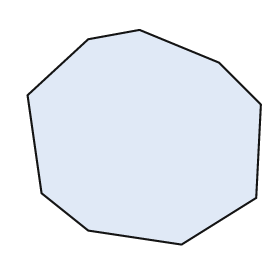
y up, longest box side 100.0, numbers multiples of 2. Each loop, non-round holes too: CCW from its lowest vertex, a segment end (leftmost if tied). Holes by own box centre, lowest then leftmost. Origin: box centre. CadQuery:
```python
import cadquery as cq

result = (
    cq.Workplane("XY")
    .moveTo(16.0, -46.0)
    .lineTo(48.0, -26.0)
    .lineTo(50.0, 14.0)
    .lineTo(32.0, 32.0)
    .lineTo(-2.0, 46.0)
    .lineTo(-24.0, 42.0)
    .lineTo(-50.0, 18.0)
    .lineTo(-44.0, -24.0)
    .lineTo(-24.0, -40.0)
    .close()
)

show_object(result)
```